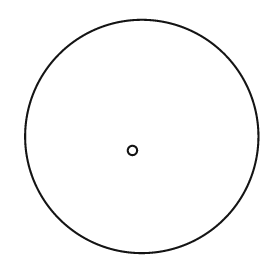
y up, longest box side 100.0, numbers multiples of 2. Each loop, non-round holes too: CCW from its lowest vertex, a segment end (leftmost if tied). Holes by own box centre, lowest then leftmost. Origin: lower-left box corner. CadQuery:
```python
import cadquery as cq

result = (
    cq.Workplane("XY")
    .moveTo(50.0, 50.0)
    .circle(50.0)
    .moveTo(46.0, 44.0)
    .circle(2.0)
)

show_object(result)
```